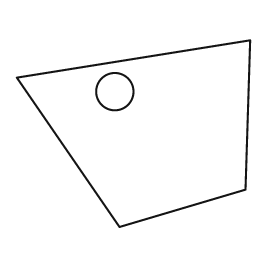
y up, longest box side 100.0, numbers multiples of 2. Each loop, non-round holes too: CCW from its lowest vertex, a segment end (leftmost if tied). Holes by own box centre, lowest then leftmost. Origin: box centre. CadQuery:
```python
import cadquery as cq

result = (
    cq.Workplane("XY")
    .moveTo(-6.0, -40.0)
    .lineTo(48.0, -24.0)
    .lineTo(50.0, 40.0)
    .lineTo(-50.0, 24.0)
    .close()
    .moveTo(-8.0, 18.0)
    .circle(8.0)
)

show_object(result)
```